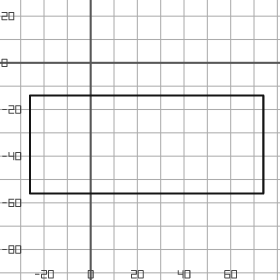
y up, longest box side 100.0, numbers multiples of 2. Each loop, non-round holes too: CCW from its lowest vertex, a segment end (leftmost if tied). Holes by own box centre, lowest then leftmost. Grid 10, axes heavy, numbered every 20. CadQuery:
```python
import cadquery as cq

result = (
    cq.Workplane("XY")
    .moveTo(-26.0, -56.0)
    .lineTo(74.0, -56.0)
    .lineTo(74.0, -14.0)
    .lineTo(-26.0, -14.0)
    .close()
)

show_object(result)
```